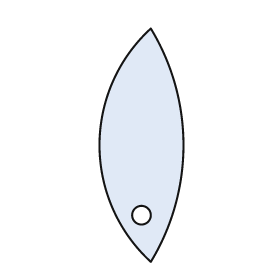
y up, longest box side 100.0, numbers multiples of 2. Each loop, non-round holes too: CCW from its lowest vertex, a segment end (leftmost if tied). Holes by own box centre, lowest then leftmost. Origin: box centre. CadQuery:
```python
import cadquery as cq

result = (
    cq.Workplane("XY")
    .moveTo(4.0, -50.0)
    .threePointArc((18.0, 0.0), (4.0, 50.0))
    .threePointArc((-18.0, 0.0), (4.0, -50.0))
    .close()
    .moveTo(0.0, -30.0)
    .circle(4.0)
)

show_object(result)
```